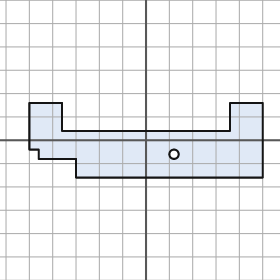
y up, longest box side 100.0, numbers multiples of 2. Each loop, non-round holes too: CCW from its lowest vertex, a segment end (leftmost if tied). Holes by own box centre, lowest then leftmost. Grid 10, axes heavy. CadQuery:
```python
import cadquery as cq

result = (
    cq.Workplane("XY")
    .moveTo(-30.0, -16.0)
    .lineTo(50.0, -16.0)
    .lineTo(50.0, 16.0)
    .lineTo(36.0, 16.0)
    .lineTo(36.0, 4.0)
    .lineTo(-36.0, 4.0)
    .lineTo(-36.0, 16.0)
    .lineTo(-50.0, 16.0)
    .lineTo(-50.0, -4.0)
    .lineTo(-46.0, -4.0)
    .lineTo(-46.0, -8.0)
    .lineTo(-30.0, -8.0)
    .close()
    .moveTo(12.0, -6.0)
    .circle(2.0)
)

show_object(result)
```